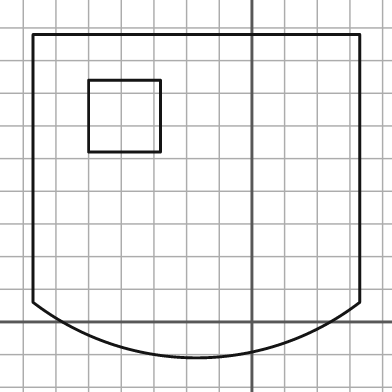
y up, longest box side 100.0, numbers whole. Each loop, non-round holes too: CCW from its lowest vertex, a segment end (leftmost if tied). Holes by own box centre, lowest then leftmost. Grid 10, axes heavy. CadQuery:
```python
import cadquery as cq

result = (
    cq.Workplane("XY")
    .moveTo(-67.0, 6.0)
    .threePointArc((-17.0, -11.0), (33.0, 6.0))
    .lineTo(33.0, 88.0)
    .lineTo(-67.0, 88.0)
    .close()
    .moveTo(-50.0, 52.0)
    .lineTo(-28.0, 52.0)
    .lineTo(-28.0, 74.0)
    .lineTo(-50.0, 74.0)
    .close()
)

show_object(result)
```